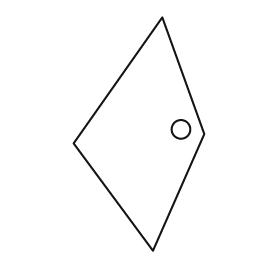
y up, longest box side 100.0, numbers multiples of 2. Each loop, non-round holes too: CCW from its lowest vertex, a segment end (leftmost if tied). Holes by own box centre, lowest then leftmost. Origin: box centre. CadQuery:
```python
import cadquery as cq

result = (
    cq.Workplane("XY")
    .moveTo(6.0, -50.0)
    .lineTo(28.0, 0.0)
    .lineTo(10.0, 50.0)
    .lineTo(-28.0, -4.0)
    .close()
    .moveTo(18.0, 2.0)
    .circle(4.0)
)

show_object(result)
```